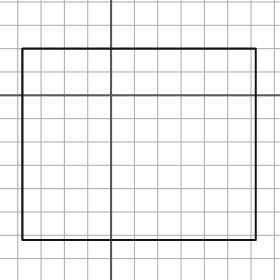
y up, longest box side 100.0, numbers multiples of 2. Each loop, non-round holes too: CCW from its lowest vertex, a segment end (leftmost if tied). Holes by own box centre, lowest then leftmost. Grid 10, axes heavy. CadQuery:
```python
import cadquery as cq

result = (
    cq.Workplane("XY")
    .moveTo(-38.0, -62.0)
    .lineTo(62.0, -62.0)
    .lineTo(62.0, 20.0)
    .lineTo(-38.0, 20.0)
    .close()
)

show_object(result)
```